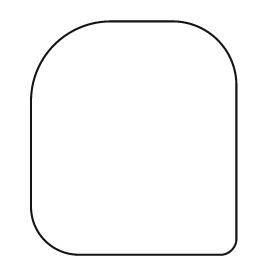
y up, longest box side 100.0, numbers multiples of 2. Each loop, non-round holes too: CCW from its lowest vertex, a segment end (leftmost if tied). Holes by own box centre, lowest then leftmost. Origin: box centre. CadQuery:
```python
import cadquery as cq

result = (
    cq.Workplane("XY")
    .moveTo(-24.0, -50.0)
    .lineTo(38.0, -50.0)
    .threePointArc((42.0, -48.0), (44.0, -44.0))
    .lineTo(44.0, 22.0)
    .threePointArc((36.0, 42.0), (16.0, 50.0))
    .lineTo(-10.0, 50.0)
    .threePointArc((-34.0, 40.0), (-44.0, 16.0))
    .lineTo(-44.0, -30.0)
    .threePointArc((-38.0, -44.0), (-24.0, -50.0))
    .close()
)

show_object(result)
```